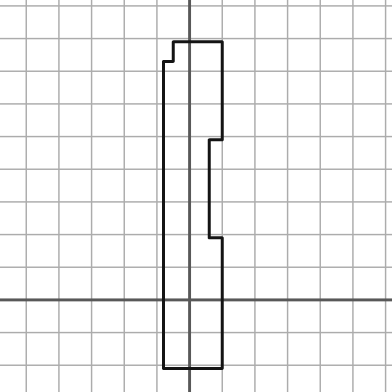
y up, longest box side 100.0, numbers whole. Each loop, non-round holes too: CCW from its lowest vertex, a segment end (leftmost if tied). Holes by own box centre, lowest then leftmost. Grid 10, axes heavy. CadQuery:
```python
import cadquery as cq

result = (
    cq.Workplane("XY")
    .moveTo(-8.0, -21.0)
    .lineTo(10.0, -21.0)
    .lineTo(10.0, 19.0)
    .lineTo(6.0, 19.0)
    .lineTo(6.0, 49.0)
    .lineTo(10.0, 49.0)
    .lineTo(10.0, 79.0)
    .lineTo(-5.0, 79.0)
    .lineTo(-5.0, 73.0)
    .lineTo(-8.0, 73.0)
    .close()
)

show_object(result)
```